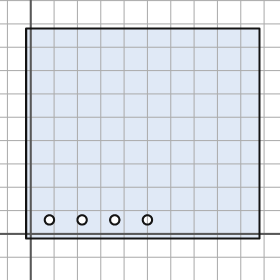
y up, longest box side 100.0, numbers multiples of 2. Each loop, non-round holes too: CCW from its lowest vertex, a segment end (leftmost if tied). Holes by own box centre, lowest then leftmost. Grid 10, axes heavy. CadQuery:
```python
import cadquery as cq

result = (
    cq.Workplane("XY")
    .moveTo(-2.0, -2.0)
    .lineTo(98.0, -2.0)
    .lineTo(98.0, 88.0)
    .lineTo(-2.0, 88.0)
    .close()
    .moveTo(8.0, 6.0)
    .circle(2.0)
    .moveTo(22.0, 6.0)
    .circle(2.0)
    .moveTo(36.0, 6.0)
    .circle(2.0)
    .moveTo(50.0, 6.0)
    .circle(2.0)
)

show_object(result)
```